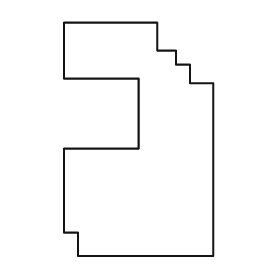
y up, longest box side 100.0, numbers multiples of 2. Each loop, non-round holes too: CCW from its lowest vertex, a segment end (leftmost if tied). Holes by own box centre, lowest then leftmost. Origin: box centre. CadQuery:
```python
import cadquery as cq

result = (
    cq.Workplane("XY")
    .moveTo(-26.0, -50.0)
    .lineTo(32.0, -50.0)
    .lineTo(32.0, 24.0)
    .lineTo(22.0, 24.0)
    .lineTo(22.0, 32.0)
    .lineTo(16.0, 32.0)
    .lineTo(16.0, 38.0)
    .lineTo(8.0, 38.0)
    .lineTo(8.0, 50.0)
    .lineTo(-32.0, 50.0)
    .lineTo(-32.0, 26.0)
    .lineTo(0.0, 26.0)
    .lineTo(0.0, -4.0)
    .lineTo(-32.0, -4.0)
    .lineTo(-32.0, -40.0)
    .lineTo(-26.0, -40.0)
    .close()
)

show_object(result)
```